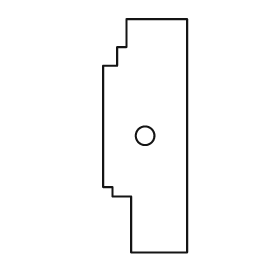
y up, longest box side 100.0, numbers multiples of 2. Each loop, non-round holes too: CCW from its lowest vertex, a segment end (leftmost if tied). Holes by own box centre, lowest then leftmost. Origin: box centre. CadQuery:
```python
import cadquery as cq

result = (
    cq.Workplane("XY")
    .moveTo(-6.0, -50.0)
    .lineTo(18.0, -50.0)
    .lineTo(18.0, 50.0)
    .lineTo(-8.0, 50.0)
    .lineTo(-8.0, 38.0)
    .lineTo(-12.0, 38.0)
    .lineTo(-12.0, 30.0)
    .lineTo(-18.0, 30.0)
    .lineTo(-18.0, -22.0)
    .lineTo(-14.0, -22.0)
    .lineTo(-14.0, -26.0)
    .lineTo(-6.0, -26.0)
    .close()
    .moveTo(0.0, 0.0)
    .circle(4.0)
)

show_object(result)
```